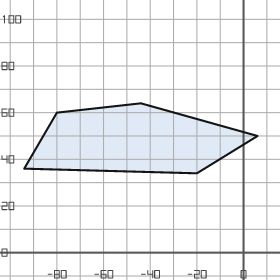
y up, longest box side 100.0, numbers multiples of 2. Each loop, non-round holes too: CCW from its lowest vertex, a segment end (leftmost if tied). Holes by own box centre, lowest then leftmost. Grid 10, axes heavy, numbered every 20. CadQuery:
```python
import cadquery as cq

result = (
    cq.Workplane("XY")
    .moveTo(-20.0, 34.0)
    .lineTo(6.0, 50.0)
    .lineTo(-44.0, 64.0)
    .lineTo(-80.0, 60.0)
    .lineTo(-94.0, 36.0)
    .close()
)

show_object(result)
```